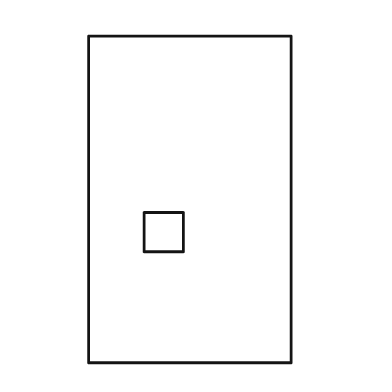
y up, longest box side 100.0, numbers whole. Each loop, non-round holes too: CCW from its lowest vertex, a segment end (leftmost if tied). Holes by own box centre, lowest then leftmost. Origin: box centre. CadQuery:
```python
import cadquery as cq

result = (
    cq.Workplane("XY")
    .moveTo(-31.0, -50.0)
    .lineTo(31.0, -50.0)
    .lineTo(31.0, 50.0)
    .lineTo(-31.0, 50.0)
    .close()
    .moveTo(-14.0, -16.0)
    .lineTo(-2.0, -16.0)
    .lineTo(-2.0, -4.0)
    .lineTo(-14.0, -4.0)
    .close()
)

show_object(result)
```